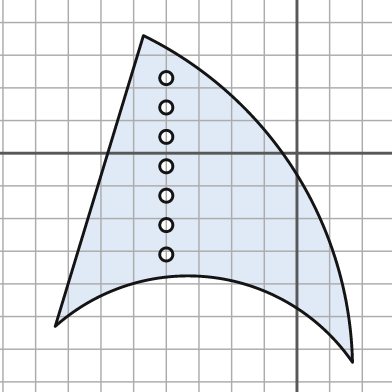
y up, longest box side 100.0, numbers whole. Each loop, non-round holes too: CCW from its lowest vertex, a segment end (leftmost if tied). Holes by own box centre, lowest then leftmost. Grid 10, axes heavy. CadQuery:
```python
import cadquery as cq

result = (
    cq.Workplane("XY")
    .moveTo(17.0, -64.0)
    .threePointArc((-1.0, -5.0), (-47.0, 36.0))
    .lineTo(-74.0, -53.0)
    .threePointArc((-26.0, -38.0), (17.0, -64.0))
    .close()
    .moveTo(-40.0, -31.0)
    .circle(2.0)
    .moveTo(-40.0, -22.0)
    .circle(2.0)
    .moveTo(-40.0, -13.0)
    .circle(2.0)
    .moveTo(-40.0, -4.0)
    .circle(2.0)
    .moveTo(-40.0, 5.0)
    .circle(2.0)
    .moveTo(-40.0, 14.0)
    .circle(2.0)
    .moveTo(-40.0, 23.0)
    .circle(2.0)
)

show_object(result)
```